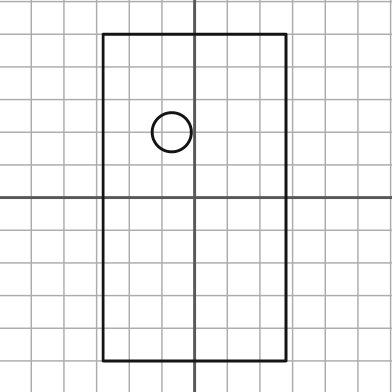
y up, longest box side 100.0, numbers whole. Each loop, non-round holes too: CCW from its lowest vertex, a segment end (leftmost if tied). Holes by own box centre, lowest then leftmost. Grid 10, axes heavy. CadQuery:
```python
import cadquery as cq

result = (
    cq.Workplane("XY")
    .moveTo(-28.0, -50.0)
    .lineTo(28.0, -50.0)
    .lineTo(28.0, 50.0)
    .lineTo(-28.0, 50.0)
    .close()
    .moveTo(-7.0, 20.0)
    .circle(6.0)
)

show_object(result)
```